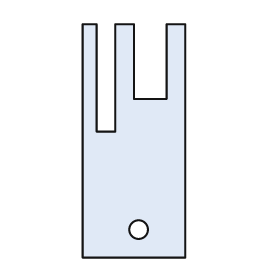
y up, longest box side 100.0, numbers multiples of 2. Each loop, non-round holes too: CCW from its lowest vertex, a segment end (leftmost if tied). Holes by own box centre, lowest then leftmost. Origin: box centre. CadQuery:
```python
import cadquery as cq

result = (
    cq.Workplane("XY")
    .moveTo(-22.0, -50.0)
    .lineTo(22.0, -50.0)
    .lineTo(22.0, 50.0)
    .lineTo(14.0, 50.0)
    .lineTo(14.0, 18.0)
    .lineTo(0.0, 18.0)
    .lineTo(0.0, 50.0)
    .lineTo(-8.0, 50.0)
    .lineTo(-8.0, 4.0)
    .lineTo(-16.0, 4.0)
    .lineTo(-16.0, 50.0)
    .lineTo(-22.0, 50.0)
    .close()
    .moveTo(2.0, -38.0)
    .circle(4.0)
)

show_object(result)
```